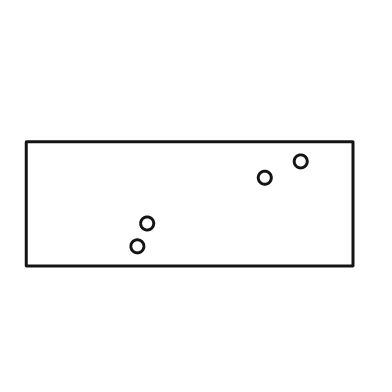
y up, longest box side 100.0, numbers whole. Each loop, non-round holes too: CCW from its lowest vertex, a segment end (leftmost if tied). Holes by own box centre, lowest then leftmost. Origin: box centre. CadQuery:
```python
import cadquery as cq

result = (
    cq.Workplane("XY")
    .moveTo(-50.0, -19.0)
    .lineTo(50.0, -19.0)
    .lineTo(50.0, 19.0)
    .lineTo(-50.0, 19.0)
    .close()
    .moveTo(-16.0, -13.0)
    .circle(2.0)
    .moveTo(-13.0, -6.0)
    .circle(2.0)
    .moveTo(23.0, 8.0)
    .circle(2.0)
    .moveTo(34.0, 13.0)
    .circle(2.0)
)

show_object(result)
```